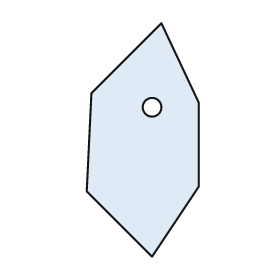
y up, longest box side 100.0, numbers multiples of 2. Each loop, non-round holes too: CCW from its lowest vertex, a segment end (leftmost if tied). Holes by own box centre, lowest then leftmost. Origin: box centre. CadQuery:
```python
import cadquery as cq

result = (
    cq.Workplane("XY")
    .moveTo(4.0, -50.0)
    .lineTo(24.0, -20.0)
    .lineTo(24.0, 16.0)
    .lineTo(8.0, 50.0)
    .lineTo(-22.0, 20.0)
    .lineTo(-24.0, -22.0)
    .close()
    .moveTo(4.0, 14.0)
    .circle(4.0)
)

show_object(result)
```